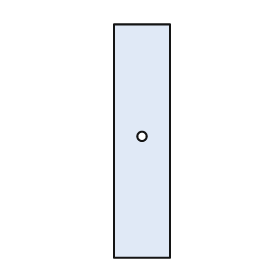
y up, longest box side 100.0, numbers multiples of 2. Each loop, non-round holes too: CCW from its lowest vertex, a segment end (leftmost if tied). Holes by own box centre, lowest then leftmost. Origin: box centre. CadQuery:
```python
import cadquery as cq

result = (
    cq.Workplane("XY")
    .moveTo(-12.0, -50.0)
    .lineTo(12.0, -50.0)
    .lineTo(12.0, 50.0)
    .lineTo(-12.0, 50.0)
    .close()
    .moveTo(0.0, 2.0)
    .circle(2.0)
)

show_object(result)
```